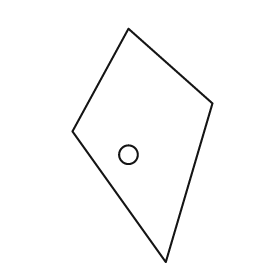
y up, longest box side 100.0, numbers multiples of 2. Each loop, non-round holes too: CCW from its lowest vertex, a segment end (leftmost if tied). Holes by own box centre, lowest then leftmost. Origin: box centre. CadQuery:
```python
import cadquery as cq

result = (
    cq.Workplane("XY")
    .moveTo(10.0, -50.0)
    .lineTo(30.0, 18.0)
    .lineTo(-6.0, 50.0)
    .lineTo(-30.0, 6.0)
    .close()
    .moveTo(-6.0, -4.0)
    .circle(4.0)
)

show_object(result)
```